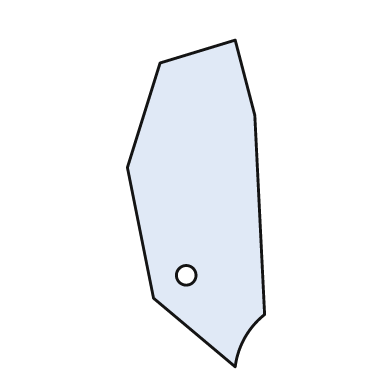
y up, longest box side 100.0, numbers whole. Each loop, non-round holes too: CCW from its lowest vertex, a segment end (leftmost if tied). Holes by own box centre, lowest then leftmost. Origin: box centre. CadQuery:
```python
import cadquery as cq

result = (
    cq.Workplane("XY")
    .moveTo(12.0, -50.0)
    .threePointArc((15.0, -41.0), (21.0, -34.0))
    .lineTo(18.0, 27.0)
    .lineTo(12.0, 50.0)
    .lineTo(-11.0, 43.0)
    .lineTo(-21.0, 11.0)
    .lineTo(-13.0, -29.0)
    .close()
    .moveTo(-3.0, -22.0)
    .circle(3.0)
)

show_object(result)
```